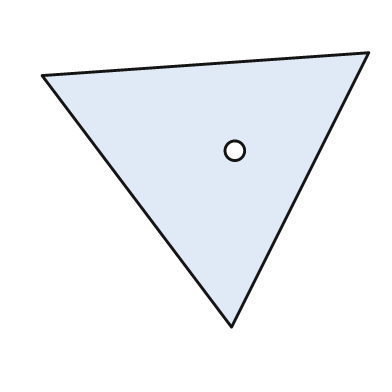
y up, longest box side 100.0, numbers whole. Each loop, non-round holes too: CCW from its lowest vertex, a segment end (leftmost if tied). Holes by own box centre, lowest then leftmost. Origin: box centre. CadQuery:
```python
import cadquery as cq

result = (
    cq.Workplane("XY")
    .moveTo(8.0, -42.0)
    .lineTo(50.0, 42.0)
    .lineTo(-50.0, 35.0)
    .close()
    .moveTo(9.0, 12.0)
    .circle(3.0)
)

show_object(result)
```